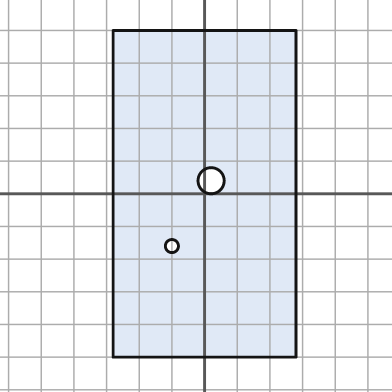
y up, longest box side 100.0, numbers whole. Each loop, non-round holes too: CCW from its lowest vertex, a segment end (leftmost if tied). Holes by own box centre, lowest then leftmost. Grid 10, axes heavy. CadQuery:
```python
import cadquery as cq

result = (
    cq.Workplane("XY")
    .moveTo(-28.0, -50.0)
    .lineTo(28.0, -50.0)
    .lineTo(28.0, 50.0)
    .lineTo(-28.0, 50.0)
    .close()
    .moveTo(-10.0, -16.0)
    .circle(2.0)
    .moveTo(2.0, 4.0)
    .circle(4.0)
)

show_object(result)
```